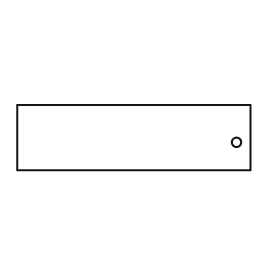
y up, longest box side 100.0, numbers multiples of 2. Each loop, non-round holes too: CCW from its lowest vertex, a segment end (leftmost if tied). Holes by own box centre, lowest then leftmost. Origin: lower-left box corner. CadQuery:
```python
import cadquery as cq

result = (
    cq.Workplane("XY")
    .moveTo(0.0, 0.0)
    .lineTo(100.0, 0.0)
    .lineTo(100.0, 28.0)
    .lineTo(0.0, 28.0)
    .close()
    .moveTo(94.0, 12.0)
    .circle(2.0)
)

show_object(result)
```